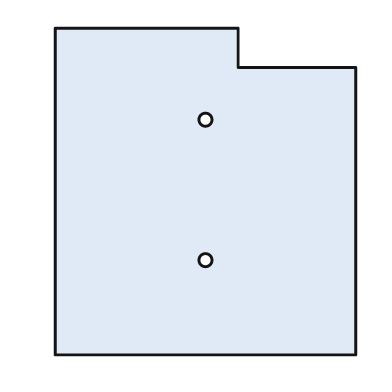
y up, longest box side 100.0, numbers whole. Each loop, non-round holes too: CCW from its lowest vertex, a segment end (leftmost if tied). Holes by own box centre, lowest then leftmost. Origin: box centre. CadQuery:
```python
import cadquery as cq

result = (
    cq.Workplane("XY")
    .moveTo(-46.0, -50.0)
    .lineTo(46.0, -50.0)
    .lineTo(46.0, 38.0)
    .lineTo(10.0, 38.0)
    .lineTo(10.0, 50.0)
    .lineTo(-46.0, 50.0)
    .close()
    .moveTo(0.0, -21.0)
    .circle(2.0)
    .moveTo(0.0, 22.0)
    .circle(2.0)
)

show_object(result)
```